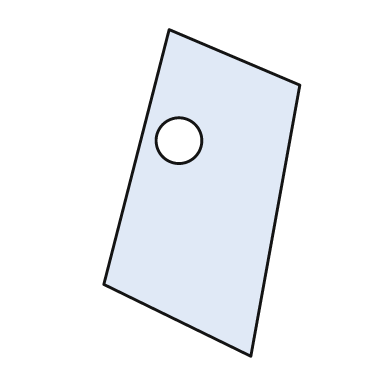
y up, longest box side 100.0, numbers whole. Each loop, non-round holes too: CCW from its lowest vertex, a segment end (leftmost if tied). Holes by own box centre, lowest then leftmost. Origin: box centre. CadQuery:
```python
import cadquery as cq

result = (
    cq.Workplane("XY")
    .moveTo(15.0, -50.0)
    .lineTo(30.0, 33.0)
    .lineTo(-10.0, 50.0)
    .lineTo(-30.0, -28.0)
    .close()
    .moveTo(-7.0, 16.0)
    .circle(7.0)
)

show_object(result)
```